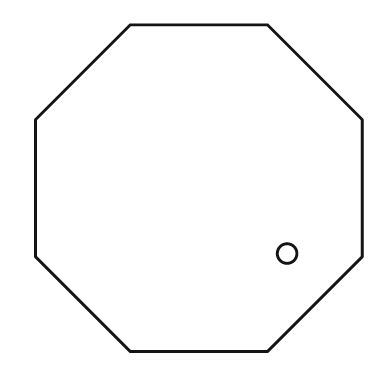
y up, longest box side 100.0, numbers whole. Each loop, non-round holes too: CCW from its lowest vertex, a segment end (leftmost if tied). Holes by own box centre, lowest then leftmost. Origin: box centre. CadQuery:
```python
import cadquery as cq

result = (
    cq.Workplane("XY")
    .moveTo(-21.0, -50.0)
    .lineTo(21.0, -50.0)
    .lineTo(50.0, -21.0)
    .lineTo(50.0, 21.0)
    .lineTo(21.0, 50.0)
    .lineTo(-21.0, 50.0)
    .lineTo(-50.0, 21.0)
    .lineTo(-50.0, -21.0)
    .close()
    .moveTo(27.0, -20.0)
    .circle(3.0)
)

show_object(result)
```